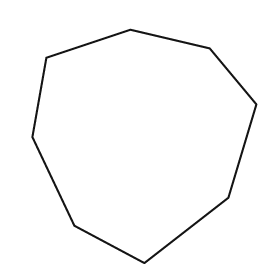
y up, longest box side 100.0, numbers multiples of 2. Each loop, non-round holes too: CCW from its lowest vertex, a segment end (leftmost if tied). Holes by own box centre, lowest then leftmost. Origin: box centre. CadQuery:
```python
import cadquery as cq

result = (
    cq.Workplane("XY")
    .moveTo(0.0, -50.0)
    .lineTo(36.0, -22.0)
    .lineTo(48.0, 18.0)
    .lineTo(28.0, 42.0)
    .lineTo(-6.0, 50.0)
    .lineTo(-42.0, 38.0)
    .lineTo(-48.0, 4.0)
    .lineTo(-30.0, -34.0)
    .close()
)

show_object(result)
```